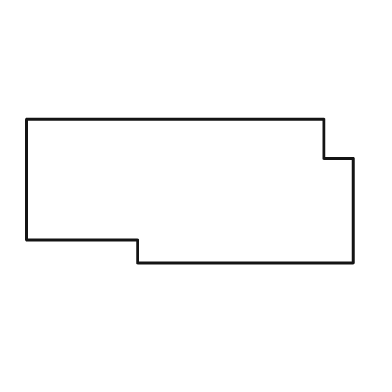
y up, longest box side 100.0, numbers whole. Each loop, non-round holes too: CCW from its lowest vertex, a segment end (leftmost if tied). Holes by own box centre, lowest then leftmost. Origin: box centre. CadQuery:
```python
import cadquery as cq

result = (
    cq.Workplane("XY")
    .moveTo(-16.0, -22.0)
    .lineTo(50.0, -22.0)
    .lineTo(50.0, 10.0)
    .lineTo(41.0, 10.0)
    .lineTo(41.0, 22.0)
    .lineTo(-50.0, 22.0)
    .lineTo(-50.0, -15.0)
    .lineTo(-16.0, -15.0)
    .close()
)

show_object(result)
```